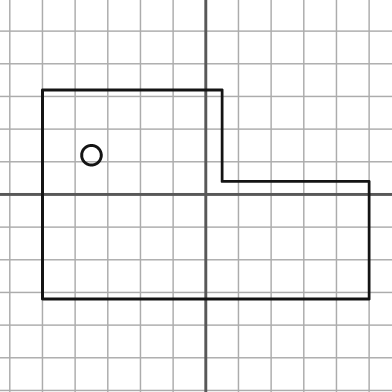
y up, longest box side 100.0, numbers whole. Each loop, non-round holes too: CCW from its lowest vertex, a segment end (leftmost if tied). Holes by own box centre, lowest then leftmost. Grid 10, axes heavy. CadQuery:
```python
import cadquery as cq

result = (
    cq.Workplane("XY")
    .moveTo(-50.0, -32.0)
    .lineTo(50.0, -32.0)
    .lineTo(50.0, 4.0)
    .lineTo(5.0, 4.0)
    .lineTo(5.0, 32.0)
    .lineTo(-50.0, 32.0)
    .close()
    .moveTo(-35.0, 12.0)
    .circle(3.0)
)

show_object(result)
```